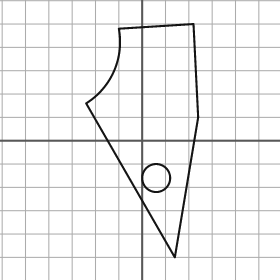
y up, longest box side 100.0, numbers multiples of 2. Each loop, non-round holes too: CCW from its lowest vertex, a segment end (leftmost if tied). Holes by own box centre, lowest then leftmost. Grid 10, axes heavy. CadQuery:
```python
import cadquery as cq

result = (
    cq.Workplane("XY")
    .moveTo(14.0, -50.0)
    .lineTo(24.0, 10.0)
    .lineTo(22.0, 50.0)
    .lineTo(-10.0, 48.0)
    .threePointArc((-12.0, 30.0), (-24.0, 16.0))
    .close()
    .moveTo(6.0, -16.0)
    .circle(6.0)
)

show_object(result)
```